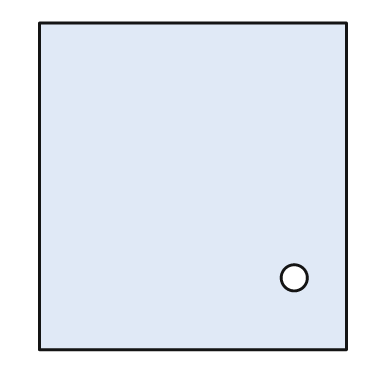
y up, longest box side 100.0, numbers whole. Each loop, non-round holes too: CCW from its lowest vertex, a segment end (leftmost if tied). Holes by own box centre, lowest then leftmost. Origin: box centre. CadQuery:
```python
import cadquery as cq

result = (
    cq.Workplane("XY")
    .moveTo(-47.0, -50.0)
    .lineTo(47.0, -50.0)
    .lineTo(47.0, 50.0)
    .lineTo(-47.0, 50.0)
    .close()
    .moveTo(31.0, -28.0)
    .circle(4.0)
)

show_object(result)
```